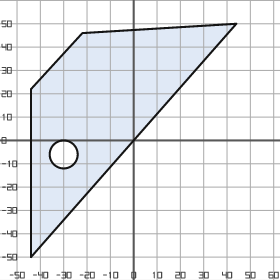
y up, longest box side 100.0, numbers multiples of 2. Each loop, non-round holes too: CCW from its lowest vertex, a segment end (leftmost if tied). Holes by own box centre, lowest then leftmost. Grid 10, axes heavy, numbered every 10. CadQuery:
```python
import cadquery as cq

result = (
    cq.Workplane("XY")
    .moveTo(-44.0, -50.0)
    .lineTo(44.0, 50.0)
    .lineTo(-22.0, 46.0)
    .lineTo(-44.0, 22.0)
    .close()
    .moveTo(-30.0, -6.0)
    .circle(6.0)
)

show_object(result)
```